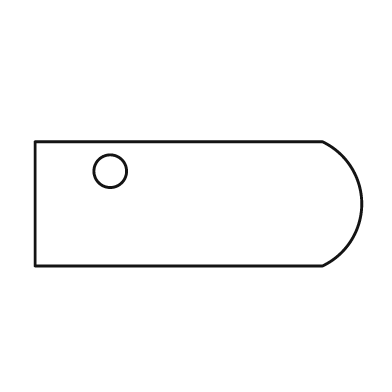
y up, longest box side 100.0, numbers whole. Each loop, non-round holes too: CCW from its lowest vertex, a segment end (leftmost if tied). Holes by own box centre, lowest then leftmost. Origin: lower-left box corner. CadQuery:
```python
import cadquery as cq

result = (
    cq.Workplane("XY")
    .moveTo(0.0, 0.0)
    .lineTo(88.0, 0.0)
    .threePointArc((100.0, 19.0), (88.0, 38.0))
    .lineTo(0.0, 38.0)
    .close()
    .moveTo(23.0, 29.0)
    .circle(5.0)
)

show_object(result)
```